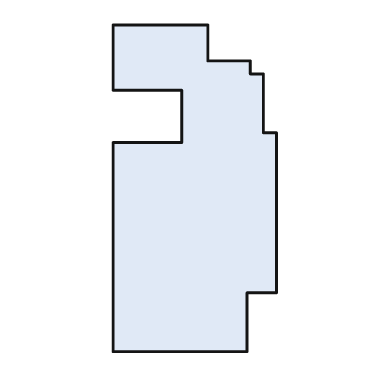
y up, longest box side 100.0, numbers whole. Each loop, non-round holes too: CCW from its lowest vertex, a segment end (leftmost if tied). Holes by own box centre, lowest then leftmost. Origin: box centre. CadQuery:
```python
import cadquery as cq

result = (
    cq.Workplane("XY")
    .moveTo(-25.0, -50.0)
    .lineTo(16.0, -50.0)
    .lineTo(16.0, -32.0)
    .lineTo(25.0, -32.0)
    .lineTo(25.0, 17.0)
    .lineTo(21.0, 17.0)
    .lineTo(21.0, 35.0)
    .lineTo(17.0, 35.0)
    .lineTo(17.0, 39.0)
    .lineTo(4.0, 39.0)
    .lineTo(4.0, 50.0)
    .lineTo(-25.0, 50.0)
    .lineTo(-25.0, 30.0)
    .lineTo(-4.0, 30.0)
    .lineTo(-4.0, 14.0)
    .lineTo(-25.0, 14.0)
    .close()
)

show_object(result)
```